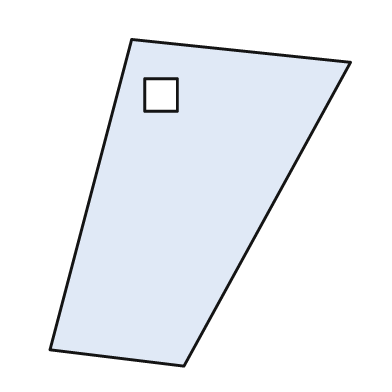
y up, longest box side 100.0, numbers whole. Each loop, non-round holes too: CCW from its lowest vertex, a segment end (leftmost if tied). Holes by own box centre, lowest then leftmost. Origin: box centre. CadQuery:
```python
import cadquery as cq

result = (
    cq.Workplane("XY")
    .moveTo(-5.0, -50.0)
    .lineTo(46.0, 43.0)
    .lineTo(-21.0, 50.0)
    .lineTo(-46.0, -45.0)
    .close()
    .moveTo(-17.0, 28.0)
    .lineTo(-7.0, 28.0)
    .lineTo(-7.0, 38.0)
    .lineTo(-17.0, 38.0)
    .close()
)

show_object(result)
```